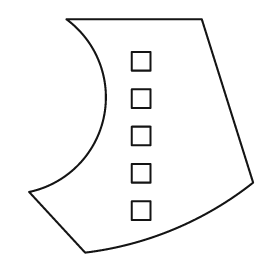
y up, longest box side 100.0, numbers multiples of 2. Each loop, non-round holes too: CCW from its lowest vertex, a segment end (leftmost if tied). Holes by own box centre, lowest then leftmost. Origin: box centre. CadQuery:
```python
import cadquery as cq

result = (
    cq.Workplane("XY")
    .moveTo(-24.0, -50.0)
    .threePointArc((14.0, -40.0), (48.0, -20.0))
    .lineTo(26.0, 50.0)
    .lineTo(-32.0, 50.0)
    .threePointArc((-16.0, 8.0), (-48.0, -24.0))
    .close()
    .moveTo(-4.0, -36.0)
    .lineTo(4.0, -36.0)
    .lineTo(4.0, -28.0)
    .lineTo(-4.0, -28.0)
    .close()
    .moveTo(-4.0, -20.0)
    .lineTo(4.0, -20.0)
    .lineTo(4.0, -12.0)
    .lineTo(-4.0, -12.0)
    .close()
    .moveTo(-4.0, -4.0)
    .lineTo(4.0, -4.0)
    .lineTo(4.0, 4.0)
    .lineTo(-4.0, 4.0)
    .close()
    .moveTo(-4.0, 12.0)
    .lineTo(4.0, 12.0)
    .lineTo(4.0, 20.0)
    .lineTo(-4.0, 20.0)
    .close()
    .moveTo(-4.0, 28.0)
    .lineTo(4.0, 28.0)
    .lineTo(4.0, 36.0)
    .lineTo(-4.0, 36.0)
    .close()
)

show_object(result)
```